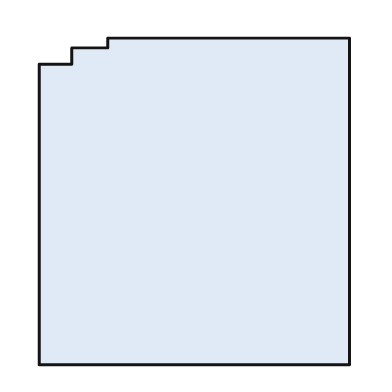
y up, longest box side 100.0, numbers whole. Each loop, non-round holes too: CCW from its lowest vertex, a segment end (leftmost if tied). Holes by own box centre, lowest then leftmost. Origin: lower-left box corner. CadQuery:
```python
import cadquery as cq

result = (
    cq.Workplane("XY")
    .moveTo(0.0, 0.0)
    .lineTo(95.0, 0.0)
    .lineTo(95.0, 100.0)
    .lineTo(21.0, 100.0)
    .lineTo(21.0, 97.0)
    .lineTo(10.0, 97.0)
    .lineTo(10.0, 92.0)
    .lineTo(0.0, 92.0)
    .close()
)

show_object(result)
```